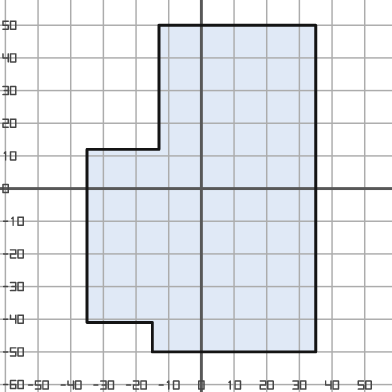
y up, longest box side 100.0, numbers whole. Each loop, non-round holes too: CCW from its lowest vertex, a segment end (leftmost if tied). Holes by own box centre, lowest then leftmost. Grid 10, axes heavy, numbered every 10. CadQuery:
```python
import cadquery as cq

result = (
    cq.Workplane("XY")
    .moveTo(-15.0, -50.0)
    .lineTo(35.0, -50.0)
    .lineTo(35.0, 50.0)
    .lineTo(-13.0, 50.0)
    .lineTo(-13.0, 12.0)
    .lineTo(-35.0, 12.0)
    .lineTo(-35.0, -41.0)
    .lineTo(-15.0, -41.0)
    .close()
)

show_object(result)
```